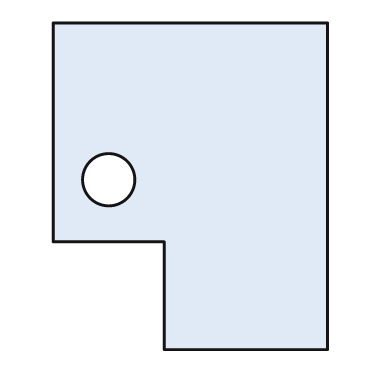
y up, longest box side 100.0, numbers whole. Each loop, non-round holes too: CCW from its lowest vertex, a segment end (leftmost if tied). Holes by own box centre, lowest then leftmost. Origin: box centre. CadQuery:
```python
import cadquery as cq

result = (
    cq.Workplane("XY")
    .moveTo(-8.0, -50.0)
    .lineTo(42.0, -50.0)
    .lineTo(42.0, 50.0)
    .lineTo(-42.0, 50.0)
    .lineTo(-42.0, -17.0)
    .lineTo(-8.0, -17.0)
    .close()
    .moveTo(-25.0, 2.0)
    .circle(8.0)
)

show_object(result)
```